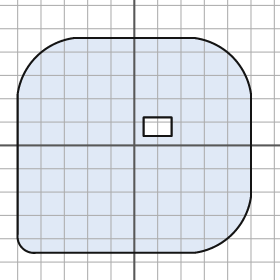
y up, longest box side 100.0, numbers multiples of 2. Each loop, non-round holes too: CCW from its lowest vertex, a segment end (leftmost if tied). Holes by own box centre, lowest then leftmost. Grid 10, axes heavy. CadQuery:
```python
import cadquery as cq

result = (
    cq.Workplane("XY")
    .moveTo(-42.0, -46.0)
    .lineTo(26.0, -46.0)
    .threePointArc((42.0, -38.0), (50.0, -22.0))
    .lineTo(50.0, 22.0)
    .threePointArc((42.0, 38.0), (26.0, 46.0))
    .lineTo(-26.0, 46.0)
    .threePointArc((-42.0, 38.0), (-50.0, 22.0))
    .lineTo(-50.0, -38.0)
    .threePointArc((-48.0, -44.0), (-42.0, -46.0))
    .close()
    .moveTo(4.0, 4.0)
    .lineTo(16.0, 4.0)
    .lineTo(16.0, 12.0)
    .lineTo(4.0, 12.0)
    .close()
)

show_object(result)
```